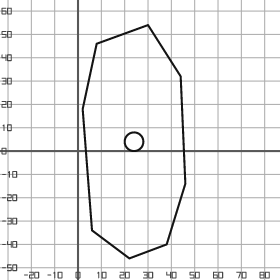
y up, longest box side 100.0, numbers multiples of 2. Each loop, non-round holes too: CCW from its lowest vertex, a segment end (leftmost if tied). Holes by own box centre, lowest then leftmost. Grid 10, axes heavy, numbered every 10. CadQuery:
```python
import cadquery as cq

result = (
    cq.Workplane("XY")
    .moveTo(22.0, -46.0)
    .lineTo(38.0, -40.0)
    .lineTo(46.0, -14.0)
    .lineTo(44.0, 32.0)
    .lineTo(30.0, 54.0)
    .lineTo(8.0, 46.0)
    .lineTo(2.0, 18.0)
    .lineTo(6.0, -34.0)
    .close()
    .moveTo(24.0, 4.0)
    .circle(4.0)
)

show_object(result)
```